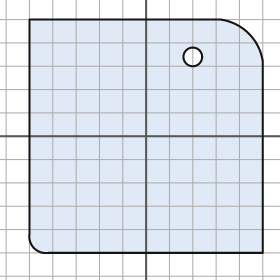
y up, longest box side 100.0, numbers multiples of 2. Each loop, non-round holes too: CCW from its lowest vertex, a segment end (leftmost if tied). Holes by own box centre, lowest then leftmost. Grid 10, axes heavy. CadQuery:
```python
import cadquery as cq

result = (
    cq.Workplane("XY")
    .moveTo(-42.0, -50.0)
    .lineTo(50.0, -50.0)
    .lineTo(50.0, 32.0)
    .threePointArc((44.0, 44.0), (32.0, 50.0))
    .lineTo(-50.0, 50.0)
    .lineTo(-50.0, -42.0)
    .threePointArc((-48.0, -48.0), (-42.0, -50.0))
    .close()
    .moveTo(20.0, 34.0)
    .circle(4.0)
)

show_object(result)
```